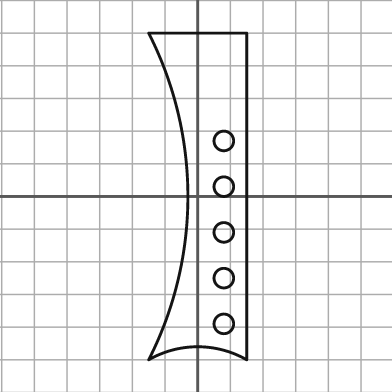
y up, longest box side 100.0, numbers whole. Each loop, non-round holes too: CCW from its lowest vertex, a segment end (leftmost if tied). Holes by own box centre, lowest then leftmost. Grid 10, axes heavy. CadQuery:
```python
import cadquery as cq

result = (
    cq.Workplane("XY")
    .moveTo(-15.0, -50.0)
    .threePointArc((0.0, -46.0), (15.0, -50.0))
    .lineTo(15.0, 50.0)
    .lineTo(-15.0, 50.0)
    .threePointArc((-3.0, 0.0), (-15.0, -50.0))
    .close()
    .moveTo(8.0, -39.0)
    .circle(3.0)
    .moveTo(8.0, -25.0)
    .circle(3.0)
    .moveTo(8.0, -11.0)
    .circle(3.0)
    .moveTo(8.0, 3.0)
    .circle(3.0)
    .moveTo(8.0, 17.0)
    .circle(3.0)
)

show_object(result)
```